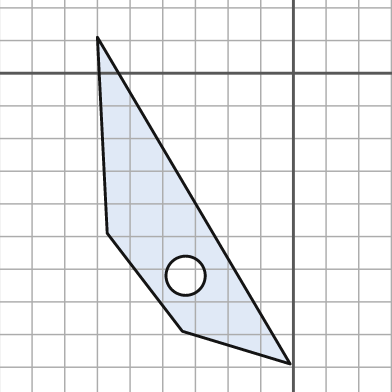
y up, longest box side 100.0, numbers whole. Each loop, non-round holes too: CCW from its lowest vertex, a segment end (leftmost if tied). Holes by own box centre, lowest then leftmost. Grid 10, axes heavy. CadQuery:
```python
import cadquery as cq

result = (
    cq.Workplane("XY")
    .moveTo(-1.0, -89.0)
    .lineTo(-60.0, 11.0)
    .lineTo(-57.0, -49.0)
    .lineTo(-34.0, -79.0)
    .close()
    .moveTo(-33.0, -62.0)
    .circle(6.0)
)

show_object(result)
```